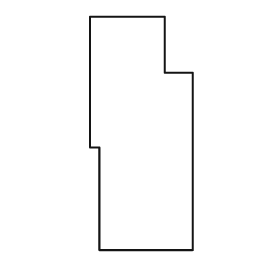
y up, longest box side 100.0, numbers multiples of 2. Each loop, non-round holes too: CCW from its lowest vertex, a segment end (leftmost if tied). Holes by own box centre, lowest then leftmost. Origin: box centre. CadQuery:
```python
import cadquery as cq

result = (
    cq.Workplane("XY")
    .moveTo(-18.0, -50.0)
    .lineTo(22.0, -50.0)
    .lineTo(22.0, 26.0)
    .lineTo(10.0, 26.0)
    .lineTo(10.0, 50.0)
    .lineTo(-22.0, 50.0)
    .lineTo(-22.0, -6.0)
    .lineTo(-18.0, -6.0)
    .close()
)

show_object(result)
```